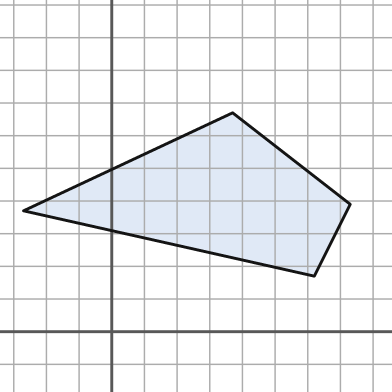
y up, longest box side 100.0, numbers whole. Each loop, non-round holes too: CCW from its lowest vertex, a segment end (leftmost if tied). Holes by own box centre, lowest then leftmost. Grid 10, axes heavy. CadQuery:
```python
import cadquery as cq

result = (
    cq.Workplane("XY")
    .moveTo(62.0, 17.0)
    .lineTo(73.0, 39.0)
    .lineTo(37.0, 67.0)
    .lineTo(-27.0, 37.0)
    .close()
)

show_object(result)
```